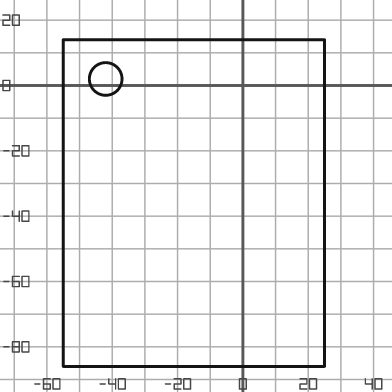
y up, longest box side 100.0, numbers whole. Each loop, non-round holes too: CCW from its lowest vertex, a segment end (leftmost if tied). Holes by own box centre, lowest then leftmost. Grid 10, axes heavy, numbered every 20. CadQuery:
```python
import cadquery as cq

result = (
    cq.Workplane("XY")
    .moveTo(-55.0, -86.0)
    .lineTo(25.0, -86.0)
    .lineTo(25.0, 14.0)
    .lineTo(-55.0, 14.0)
    .close()
    .moveTo(-42.0, 2.0)
    .circle(5.0)
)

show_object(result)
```